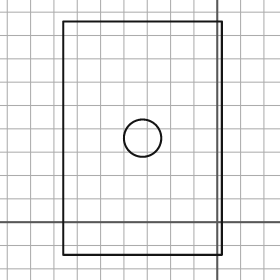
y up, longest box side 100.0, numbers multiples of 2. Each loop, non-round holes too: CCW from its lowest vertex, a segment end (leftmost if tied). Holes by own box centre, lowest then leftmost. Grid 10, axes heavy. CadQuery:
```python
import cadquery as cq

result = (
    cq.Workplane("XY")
    .moveTo(-66.0, -14.0)
    .lineTo(2.0, -14.0)
    .lineTo(2.0, 86.0)
    .lineTo(-66.0, 86.0)
    .close()
    .moveTo(-32.0, 36.0)
    .circle(8.0)
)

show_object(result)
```